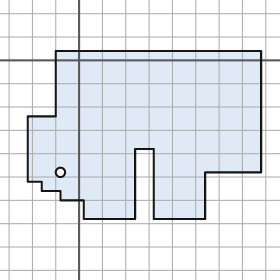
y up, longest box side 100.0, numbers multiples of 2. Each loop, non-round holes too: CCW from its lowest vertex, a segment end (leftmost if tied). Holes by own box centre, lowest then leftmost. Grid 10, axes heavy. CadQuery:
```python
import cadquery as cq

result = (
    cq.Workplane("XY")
    .moveTo(2.0, -68.0)
    .lineTo(24.0, -68.0)
    .lineTo(24.0, -38.0)
    .lineTo(32.0, -38.0)
    .lineTo(32.0, -68.0)
    .lineTo(54.0, -68.0)
    .lineTo(54.0, -48.0)
    .lineTo(78.0, -48.0)
    .lineTo(78.0, 4.0)
    .lineTo(-10.0, 4.0)
    .lineTo(-10.0, -24.0)
    .lineTo(-22.0, -24.0)
    .lineTo(-22.0, -52.0)
    .lineTo(-16.0, -52.0)
    .lineTo(-16.0, -56.0)
    .lineTo(-8.0, -56.0)
    .lineTo(-8.0, -60.0)
    .lineTo(2.0, -60.0)
    .close()
    .moveTo(-8.0, -48.0)
    .circle(2.0)
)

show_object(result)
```